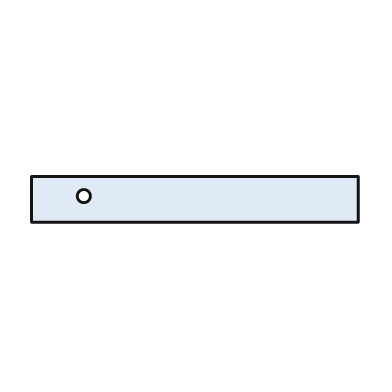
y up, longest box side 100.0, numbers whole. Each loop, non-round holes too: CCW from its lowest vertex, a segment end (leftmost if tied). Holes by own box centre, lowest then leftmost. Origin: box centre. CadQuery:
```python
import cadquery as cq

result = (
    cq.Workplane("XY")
    .moveTo(-50.0, -7.0)
    .lineTo(50.0, -7.0)
    .lineTo(50.0, 7.0)
    .lineTo(-50.0, 7.0)
    .close()
    .moveTo(-34.0, 1.0)
    .circle(2.0)
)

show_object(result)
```